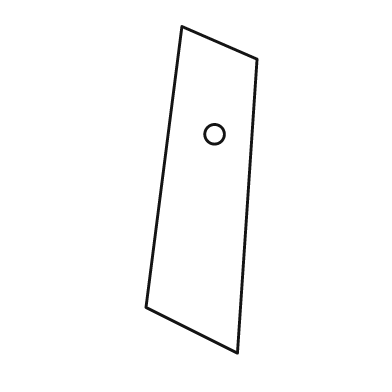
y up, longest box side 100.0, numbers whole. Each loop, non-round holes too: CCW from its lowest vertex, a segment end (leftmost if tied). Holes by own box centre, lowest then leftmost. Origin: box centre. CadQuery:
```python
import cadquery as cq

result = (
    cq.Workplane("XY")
    .moveTo(11.0, -50.0)
    .lineTo(17.0, 40.0)
    .lineTo(-6.0, 50.0)
    .lineTo(-17.0, -36.0)
    .close()
    .moveTo(4.0, 17.0)
    .circle(3.0)
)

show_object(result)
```